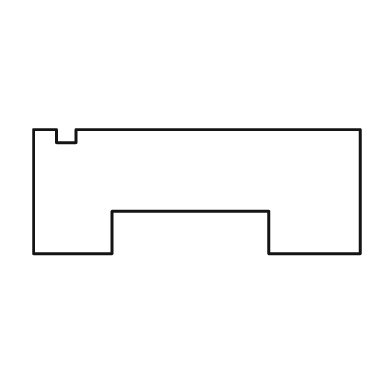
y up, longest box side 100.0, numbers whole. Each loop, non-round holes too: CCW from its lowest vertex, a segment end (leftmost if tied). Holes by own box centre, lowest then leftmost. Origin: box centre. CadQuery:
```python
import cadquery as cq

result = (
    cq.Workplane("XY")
    .moveTo(-50.0, -19.0)
    .lineTo(-26.0, -19.0)
    .lineTo(-26.0, -6.0)
    .lineTo(22.0, -6.0)
    .lineTo(22.0, -19.0)
    .lineTo(50.0, -19.0)
    .lineTo(50.0, 19.0)
    .lineTo(-37.0, 19.0)
    .lineTo(-37.0, 15.0)
    .lineTo(-43.0, 15.0)
    .lineTo(-43.0, 19.0)
    .lineTo(-50.0, 19.0)
    .close()
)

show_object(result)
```